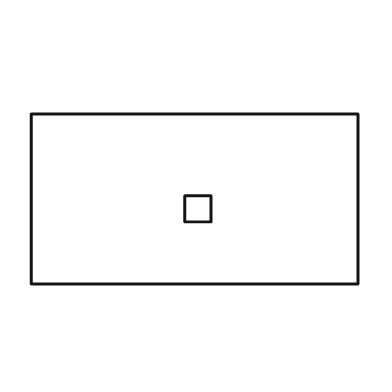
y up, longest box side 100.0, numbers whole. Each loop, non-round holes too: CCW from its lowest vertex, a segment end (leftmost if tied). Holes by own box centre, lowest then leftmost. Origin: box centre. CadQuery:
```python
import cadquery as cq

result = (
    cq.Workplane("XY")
    .moveTo(-50.0, -26.0)
    .lineTo(50.0, -26.0)
    .lineTo(50.0, 26.0)
    .lineTo(-50.0, 26.0)
    .close()
    .moveTo(-3.0, -7.0)
    .lineTo(5.0, -7.0)
    .lineTo(5.0, 1.0)
    .lineTo(-3.0, 1.0)
    .close()
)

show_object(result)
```